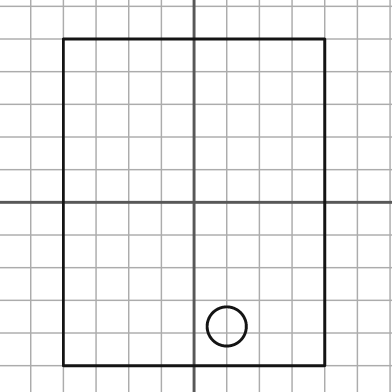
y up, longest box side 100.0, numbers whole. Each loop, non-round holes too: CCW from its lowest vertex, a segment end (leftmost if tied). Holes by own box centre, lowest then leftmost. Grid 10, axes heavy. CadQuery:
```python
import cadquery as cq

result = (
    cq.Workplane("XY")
    .moveTo(-40.0, -50.0)
    .lineTo(40.0, -50.0)
    .lineTo(40.0, 50.0)
    .lineTo(-40.0, 50.0)
    .close()
    .moveTo(10.0, -38.0)
    .circle(6.0)
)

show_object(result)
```